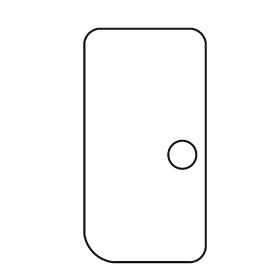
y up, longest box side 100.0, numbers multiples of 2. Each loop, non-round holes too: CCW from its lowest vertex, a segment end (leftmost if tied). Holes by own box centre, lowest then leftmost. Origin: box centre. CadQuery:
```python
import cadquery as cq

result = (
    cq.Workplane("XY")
    .moveTo(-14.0, -50.0)
    .lineTo(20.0, -50.0)
    .threePointArc((24.0, -48.0), (26.0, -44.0))
    .lineTo(26.0, 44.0)
    .threePointArc((24.0, 48.0), (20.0, 50.0))
    .lineTo(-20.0, 50.0)
    .threePointArc((-24.0, 48.0), (-26.0, 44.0))
    .lineTo(-26.0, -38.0)
    .threePointArc((-22.0, -46.0), (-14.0, -50.0))
    .close()
    .moveTo(16.0, -4.0)
    .circle(6.0)
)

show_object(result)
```